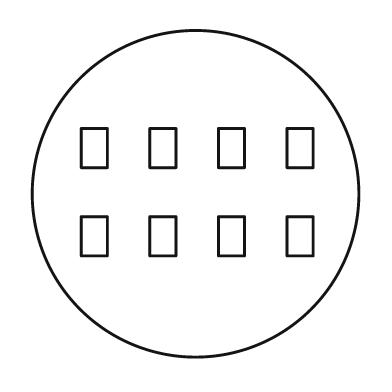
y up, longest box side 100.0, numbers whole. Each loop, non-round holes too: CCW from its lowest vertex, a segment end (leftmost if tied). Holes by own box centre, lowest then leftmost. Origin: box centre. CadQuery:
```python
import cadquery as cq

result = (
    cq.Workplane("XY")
    .moveTo(0.0, 0.0)
    .circle(50.0)
    .moveTo(-35.0, -19.0)
    .lineTo(-27.0, -19.0)
    .lineTo(-27.0, -7.0)
    .lineTo(-35.0, -7.0)
    .close()
    .moveTo(-14.0, -19.0)
    .lineTo(-6.0, -19.0)
    .lineTo(-6.0, -7.0)
    .lineTo(-14.0, -7.0)
    .close()
    .moveTo(7.0, -19.0)
    .lineTo(15.0, -19.0)
    .lineTo(15.0, -7.0)
    .lineTo(7.0, -7.0)
    .close()
    .moveTo(28.0, -19.0)
    .lineTo(36.0, -19.0)
    .lineTo(36.0, -7.0)
    .lineTo(28.0, -7.0)
    .close()
    .moveTo(-35.0, 8.0)
    .lineTo(-27.0, 8.0)
    .lineTo(-27.0, 20.0)
    .lineTo(-35.0, 20.0)
    .close()
    .moveTo(-14.0, 8.0)
    .lineTo(-6.0, 8.0)
    .lineTo(-6.0, 20.0)
    .lineTo(-14.0, 20.0)
    .close()
    .moveTo(7.0, 8.0)
    .lineTo(15.0, 8.0)
    .lineTo(15.0, 20.0)
    .lineTo(7.0, 20.0)
    .close()
    .moveTo(28.0, 8.0)
    .lineTo(36.0, 8.0)
    .lineTo(36.0, 20.0)
    .lineTo(28.0, 20.0)
    .close()
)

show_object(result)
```